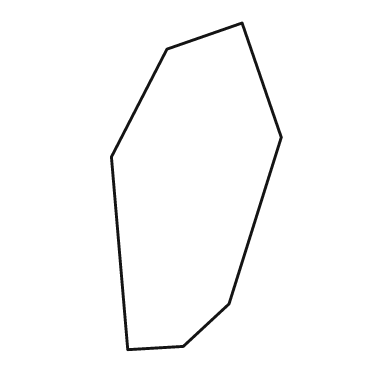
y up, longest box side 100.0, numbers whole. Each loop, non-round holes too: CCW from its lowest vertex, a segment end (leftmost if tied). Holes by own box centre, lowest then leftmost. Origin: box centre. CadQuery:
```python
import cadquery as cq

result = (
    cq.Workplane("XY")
    .moveTo(-21.0, -50.0)
    .lineTo(-4.0, -49.0)
    .lineTo(10.0, -36.0)
    .lineTo(26.0, 15.0)
    .lineTo(14.0, 50.0)
    .lineTo(-9.0, 42.0)
    .lineTo(-26.0, 9.0)
    .close()
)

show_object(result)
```